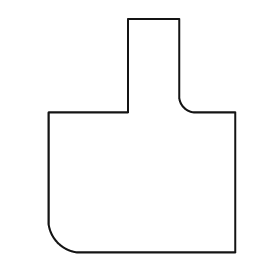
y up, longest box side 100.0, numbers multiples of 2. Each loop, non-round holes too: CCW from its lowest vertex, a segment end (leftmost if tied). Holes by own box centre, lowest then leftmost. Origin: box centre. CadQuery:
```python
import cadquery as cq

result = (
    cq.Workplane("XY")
    .moveTo(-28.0, -50.0)
    .lineTo(40.0, -50.0)
    .lineTo(40.0, 10.0)
    .lineTo(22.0, 10.0)
    .threePointArc((18.0, 12.0), (16.0, 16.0))
    .lineTo(16.0, 50.0)
    .lineTo(-6.0, 50.0)
    .lineTo(-6.0, 10.0)
    .lineTo(-40.0, 10.0)
    .lineTo(-40.0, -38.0)
    .threePointArc((-36.0, -46.0), (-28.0, -50.0))
    .close()
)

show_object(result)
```